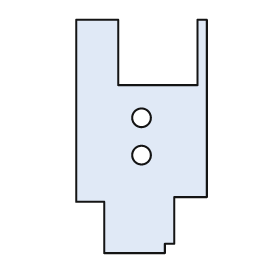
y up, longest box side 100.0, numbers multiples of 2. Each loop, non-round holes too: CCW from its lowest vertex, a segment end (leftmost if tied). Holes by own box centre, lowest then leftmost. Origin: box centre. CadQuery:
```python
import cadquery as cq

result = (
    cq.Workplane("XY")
    .moveTo(-16.0, -50.0)
    .lineTo(10.0, -50.0)
    .lineTo(10.0, -46.0)
    .lineTo(14.0, -46.0)
    .lineTo(14.0, -26.0)
    .lineTo(28.0, -26.0)
    .lineTo(28.0, 50.0)
    .lineTo(24.0, 50.0)
    .lineTo(24.0, 22.0)
    .lineTo(-10.0, 22.0)
    .lineTo(-10.0, 50.0)
    .lineTo(-28.0, 50.0)
    .lineTo(-28.0, -28.0)
    .lineTo(-16.0, -28.0)
    .close()
    .moveTo(0.0, -8.0)
    .circle(4.0)
    .moveTo(0.0, 8.0)
    .circle(4.0)
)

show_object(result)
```